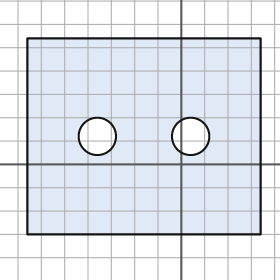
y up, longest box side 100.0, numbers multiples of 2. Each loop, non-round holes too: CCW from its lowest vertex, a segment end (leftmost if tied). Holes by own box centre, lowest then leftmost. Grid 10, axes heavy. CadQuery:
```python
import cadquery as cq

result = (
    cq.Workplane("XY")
    .moveTo(-66.0, -30.0)
    .lineTo(34.0, -30.0)
    .lineTo(34.0, 54.0)
    .lineTo(-66.0, 54.0)
    .close()
    .moveTo(-36.0, 12.0)
    .circle(8.0)
    .moveTo(4.0, 12.0)
    .circle(8.0)
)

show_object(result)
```